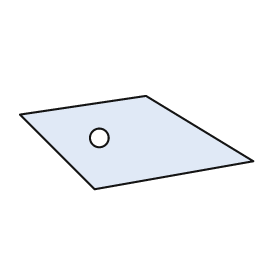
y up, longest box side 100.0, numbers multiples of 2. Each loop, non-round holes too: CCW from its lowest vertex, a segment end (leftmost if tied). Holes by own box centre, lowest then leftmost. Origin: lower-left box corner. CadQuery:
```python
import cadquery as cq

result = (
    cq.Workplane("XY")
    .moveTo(32.0, 0.0)
    .lineTo(100.0, 12.0)
    .lineTo(54.0, 40.0)
    .lineTo(0.0, 32.0)
    .close()
    .moveTo(34.0, 22.0)
    .circle(4.0)
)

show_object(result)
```